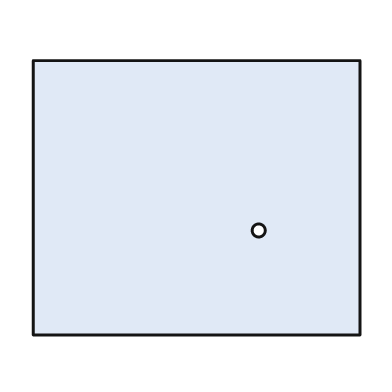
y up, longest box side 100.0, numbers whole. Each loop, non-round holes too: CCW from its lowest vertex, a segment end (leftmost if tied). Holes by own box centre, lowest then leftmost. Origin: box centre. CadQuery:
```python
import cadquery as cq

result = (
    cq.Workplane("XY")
    .moveTo(-50.0, -42.0)
    .lineTo(50.0, -42.0)
    .lineTo(50.0, 42.0)
    .lineTo(-50.0, 42.0)
    .close()
    .moveTo(19.0, -10.0)
    .circle(2.0)
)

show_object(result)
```